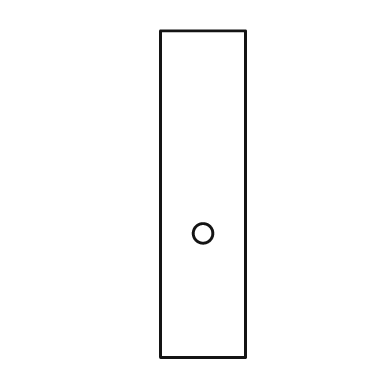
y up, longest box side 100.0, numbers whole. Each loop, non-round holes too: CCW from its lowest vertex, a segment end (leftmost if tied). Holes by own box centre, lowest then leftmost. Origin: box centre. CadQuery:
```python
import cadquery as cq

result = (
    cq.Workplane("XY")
    .moveTo(-13.0, -50.0)
    .lineTo(13.0, -50.0)
    .lineTo(13.0, 50.0)
    .lineTo(-13.0, 50.0)
    .close()
    .moveTo(0.0, -12.0)
    .circle(3.0)
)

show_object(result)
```